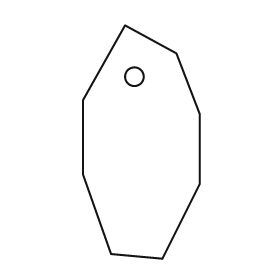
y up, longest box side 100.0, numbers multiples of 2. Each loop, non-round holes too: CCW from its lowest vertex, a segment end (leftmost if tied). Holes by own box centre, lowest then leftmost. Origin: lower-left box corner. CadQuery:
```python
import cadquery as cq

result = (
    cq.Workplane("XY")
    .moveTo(34.0, 0.0)
    .lineTo(50.0, 32.0)
    .lineTo(50.0, 62.0)
    .lineTo(40.0, 88.0)
    .lineTo(18.0, 100.0)
    .lineTo(0.0, 68.0)
    .lineTo(0.0, 36.0)
    .lineTo(12.0, 2.0)
    .close()
    .moveTo(22.0, 78.0)
    .circle(4.0)
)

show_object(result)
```